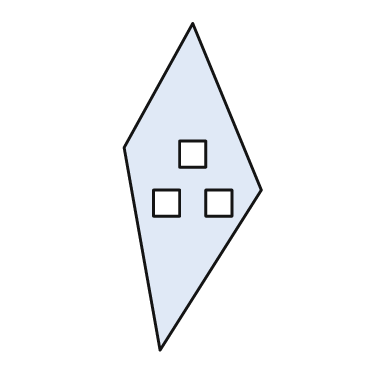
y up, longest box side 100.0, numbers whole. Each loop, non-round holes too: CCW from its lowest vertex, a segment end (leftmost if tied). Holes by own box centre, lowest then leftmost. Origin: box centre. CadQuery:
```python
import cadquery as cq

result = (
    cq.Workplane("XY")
    .moveTo(-10.0, -50.0)
    .lineTo(21.0, -1.0)
    .lineTo(0.0, 50.0)
    .lineTo(-21.0, 12.0)
    .close()
    .moveTo(-12.0, -9.0)
    .lineTo(-4.0, -9.0)
    .lineTo(-4.0, -1.0)
    .lineTo(-12.0, -1.0)
    .close()
    .moveTo(4.0, -9.0)
    .lineTo(12.0, -9.0)
    .lineTo(12.0, -1.0)
    .lineTo(4.0, -1.0)
    .close()
    .moveTo(-4.0, 6.0)
    .lineTo(4.0, 6.0)
    .lineTo(4.0, 14.0)
    .lineTo(-4.0, 14.0)
    .close()
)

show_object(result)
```